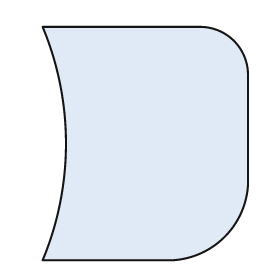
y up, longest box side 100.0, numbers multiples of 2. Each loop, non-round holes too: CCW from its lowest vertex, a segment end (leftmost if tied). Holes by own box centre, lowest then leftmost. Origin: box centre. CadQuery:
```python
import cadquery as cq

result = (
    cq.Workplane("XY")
    .moveTo(-44.0, -50.0)
    .lineTo(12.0, -50.0)
    .threePointArc((34.0, -40.0), (44.0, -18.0))
    .lineTo(44.0, 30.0)
    .threePointArc((38.0, 44.0), (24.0, 50.0))
    .lineTo(-44.0, 50.0)
    .threePointArc((-34.0, 0.0), (-44.0, -50.0))
    .close()
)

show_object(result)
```